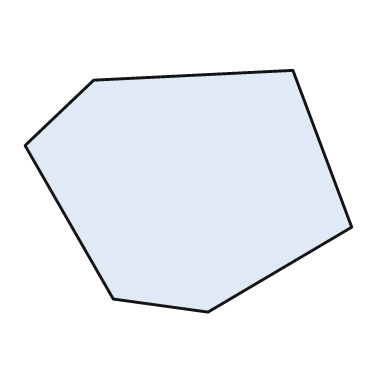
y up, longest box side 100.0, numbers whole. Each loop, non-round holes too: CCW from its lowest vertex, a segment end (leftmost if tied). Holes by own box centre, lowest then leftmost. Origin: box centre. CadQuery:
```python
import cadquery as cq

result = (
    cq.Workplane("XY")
    .moveTo(6.0, -37.0)
    .lineTo(50.0, -11.0)
    .lineTo(32.0, 37.0)
    .lineTo(-29.0, 34.0)
    .lineTo(-50.0, 14.0)
    .lineTo(-23.0, -33.0)
    .close()
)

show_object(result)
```